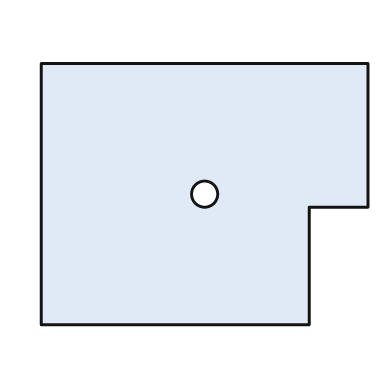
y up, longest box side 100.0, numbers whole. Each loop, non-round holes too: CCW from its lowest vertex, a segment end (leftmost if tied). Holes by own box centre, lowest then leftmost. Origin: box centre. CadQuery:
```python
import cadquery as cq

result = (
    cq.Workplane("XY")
    .moveTo(-50.0, -40.0)
    .lineTo(32.0, -40.0)
    .lineTo(32.0, -4.0)
    .lineTo(50.0, -4.0)
    .lineTo(50.0, 40.0)
    .lineTo(-50.0, 40.0)
    .close()
    .moveTo(0.0, 0.0)
    .circle(4.0)
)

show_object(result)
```